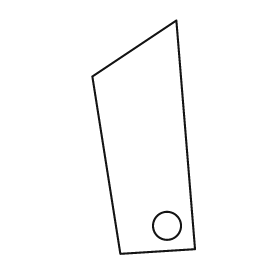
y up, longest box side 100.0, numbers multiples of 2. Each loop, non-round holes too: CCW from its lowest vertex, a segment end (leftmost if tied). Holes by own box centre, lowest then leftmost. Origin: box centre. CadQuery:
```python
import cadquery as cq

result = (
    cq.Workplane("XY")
    .moveTo(-10.0, -50.0)
    .lineTo(22.0, -48.0)
    .lineTo(14.0, 50.0)
    .lineTo(-22.0, 26.0)
    .close()
    .moveTo(10.0, -38.0)
    .circle(6.0)
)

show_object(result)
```